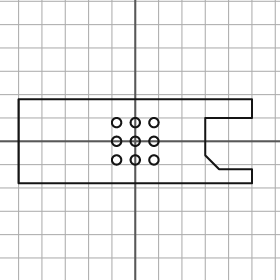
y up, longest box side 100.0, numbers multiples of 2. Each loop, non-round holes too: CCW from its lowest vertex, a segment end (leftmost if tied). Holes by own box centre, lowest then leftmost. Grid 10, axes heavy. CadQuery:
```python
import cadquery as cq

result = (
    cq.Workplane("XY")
    .moveTo(-50.0, -18.0)
    .lineTo(50.0, -18.0)
    .lineTo(50.0, -12.0)
    .lineTo(36.0, -12.0)
    .lineTo(30.0, -6.0)
    .lineTo(30.0, 10.0)
    .lineTo(50.0, 10.0)
    .lineTo(50.0, 18.0)
    .lineTo(-50.0, 18.0)
    .close()
    .moveTo(-8.0, -8.0)
    .circle(2.0)
    .moveTo(0.0, -8.0)
    .circle(2.0)
    .moveTo(8.0, -8.0)
    .circle(2.0)
    .moveTo(-8.0, 0.0)
    .circle(2.0)
    .moveTo(0.0, 0.0)
    .circle(2.0)
    .moveTo(8.0, 0.0)
    .circle(2.0)
    .moveTo(-8.0, 8.0)
    .circle(2.0)
    .moveTo(0.0, 8.0)
    .circle(2.0)
    .moveTo(8.0, 8.0)
    .circle(2.0)
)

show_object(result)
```